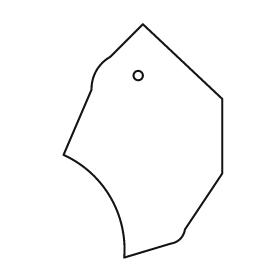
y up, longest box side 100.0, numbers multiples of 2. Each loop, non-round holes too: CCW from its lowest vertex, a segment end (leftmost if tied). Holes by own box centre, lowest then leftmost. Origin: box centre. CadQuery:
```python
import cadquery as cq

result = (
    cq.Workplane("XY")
    .moveTo(-8.0, -50.0)
    .lineTo(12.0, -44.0)
    .threePointArc((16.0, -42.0), (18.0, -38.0))
    .lineTo(34.0, -14.0)
    .lineTo(34.0, 18.0)
    .lineTo(0.0, 50.0)
    .lineTo(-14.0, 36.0)
    .threePointArc((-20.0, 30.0), (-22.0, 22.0))
    .lineTo(-34.0, -6.0)
    .threePointArc((-14.0, -24.0), (-8.0, -50.0))
    .close()
    .moveTo(-2.0, 28.0)
    .circle(2.0)
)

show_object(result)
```